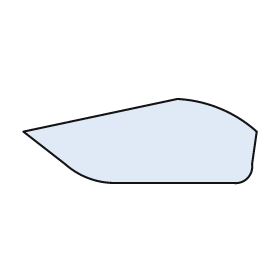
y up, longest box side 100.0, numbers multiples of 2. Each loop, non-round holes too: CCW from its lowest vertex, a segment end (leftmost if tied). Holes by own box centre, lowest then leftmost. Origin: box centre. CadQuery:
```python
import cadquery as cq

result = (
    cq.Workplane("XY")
    .moveTo(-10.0, -18.0)
    .lineTo(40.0, -18.0)
    .threePointArc((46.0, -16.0), (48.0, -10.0))
    .lineTo(50.0, 4.0)
    .threePointArc((34.0, 14.0), (16.0, 18.0))
    .lineTo(-50.0, 4.0)
    .lineTo(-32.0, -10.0)
    .threePointArc((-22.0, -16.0), (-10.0, -18.0))
    .close()
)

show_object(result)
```